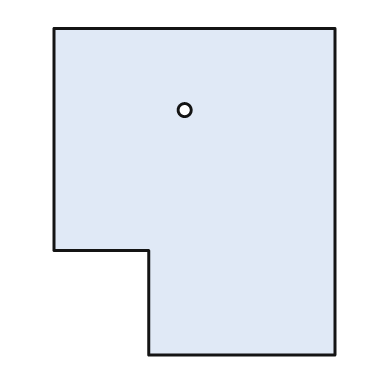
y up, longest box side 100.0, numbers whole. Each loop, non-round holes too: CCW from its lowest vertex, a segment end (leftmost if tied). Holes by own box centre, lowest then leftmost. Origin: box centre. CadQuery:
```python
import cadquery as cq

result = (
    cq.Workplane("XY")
    .moveTo(-14.0, -50.0)
    .lineTo(43.0, -50.0)
    .lineTo(43.0, 50.0)
    .lineTo(-43.0, 50.0)
    .lineTo(-43.0, -18.0)
    .lineTo(-14.0, -18.0)
    .close()
    .moveTo(-3.0, 25.0)
    .circle(2.0)
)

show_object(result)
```